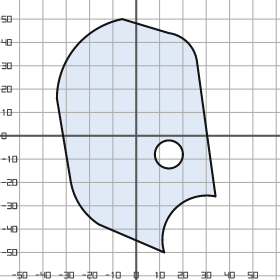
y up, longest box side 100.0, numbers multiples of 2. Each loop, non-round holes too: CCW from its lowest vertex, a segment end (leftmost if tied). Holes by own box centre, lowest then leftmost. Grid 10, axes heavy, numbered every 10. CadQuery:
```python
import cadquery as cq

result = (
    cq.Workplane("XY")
    .moveTo(12.0, -50.0)
    .threePointArc((16.0, -32.0), (34.0, -26.0))
    .lineTo(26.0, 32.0)
    .threePointArc((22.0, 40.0), (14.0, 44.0))
    .lineTo(-6.0, 50.0)
    .threePointArc((-26.0, 38.0), (-34.0, 16.0))
    .lineTo(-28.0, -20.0)
    .threePointArc((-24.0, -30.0), (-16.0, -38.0))
    .close()
    .moveTo(14.0, -8.0)
    .circle(6.0)
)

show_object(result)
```